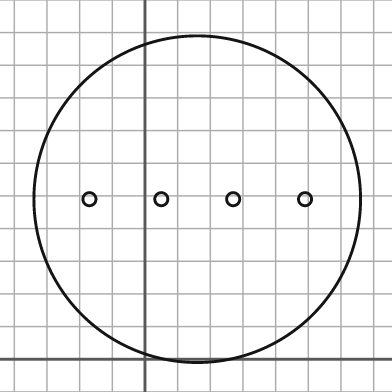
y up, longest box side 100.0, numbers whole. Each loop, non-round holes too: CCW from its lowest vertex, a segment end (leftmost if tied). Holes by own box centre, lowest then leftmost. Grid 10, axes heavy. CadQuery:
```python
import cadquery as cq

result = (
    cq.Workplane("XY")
    .moveTo(16.0, 49.0)
    .circle(50.0)
    .moveTo(-17.0, 49.0)
    .circle(2.0)
    .moveTo(5.0, 49.0)
    .circle(2.0)
    .moveTo(27.0, 49.0)
    .circle(2.0)
    .moveTo(49.0, 49.0)
    .circle(2.0)
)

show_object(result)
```